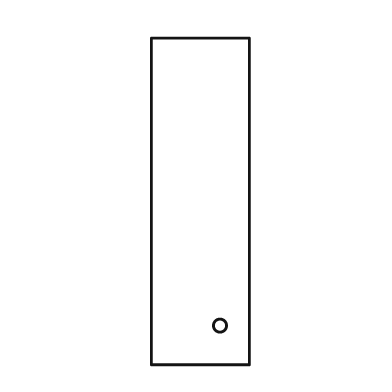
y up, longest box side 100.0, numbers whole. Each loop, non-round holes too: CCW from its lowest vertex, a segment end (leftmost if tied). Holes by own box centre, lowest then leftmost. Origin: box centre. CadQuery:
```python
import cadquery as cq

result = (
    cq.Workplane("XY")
    .moveTo(-15.0, -50.0)
    .lineTo(15.0, -50.0)
    .lineTo(15.0, 50.0)
    .lineTo(-15.0, 50.0)
    .close()
    .moveTo(6.0, -38.0)
    .circle(2.0)
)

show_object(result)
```